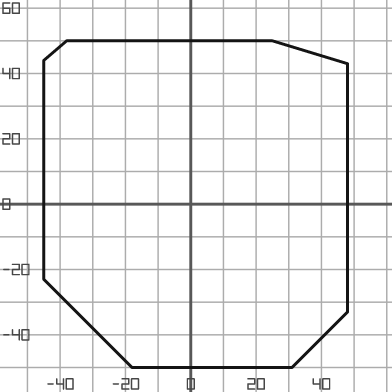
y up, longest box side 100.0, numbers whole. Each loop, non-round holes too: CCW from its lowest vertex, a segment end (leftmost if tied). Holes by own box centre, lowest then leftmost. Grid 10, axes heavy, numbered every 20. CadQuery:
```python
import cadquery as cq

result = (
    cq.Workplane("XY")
    .moveTo(-18.0, -50.0)
    .lineTo(31.0, -50.0)
    .lineTo(48.0, -33.0)
    .lineTo(48.0, 43.0)
    .lineTo(25.0, 50.0)
    .lineTo(-38.0, 50.0)
    .lineTo(-45.0, 44.0)
    .lineTo(-45.0, -23.0)
    .close()
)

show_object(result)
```